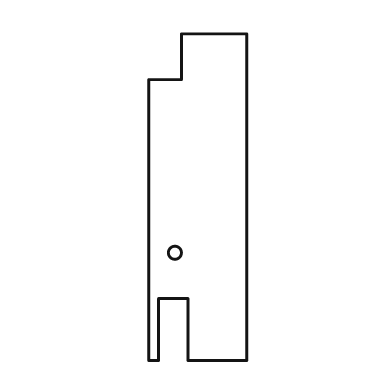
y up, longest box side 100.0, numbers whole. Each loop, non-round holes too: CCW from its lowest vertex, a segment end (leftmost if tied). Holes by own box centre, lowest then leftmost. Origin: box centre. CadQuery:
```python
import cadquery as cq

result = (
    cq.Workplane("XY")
    .moveTo(-15.0, -50.0)
    .lineTo(-12.0, -50.0)
    .lineTo(-12.0, -31.0)
    .lineTo(-3.0, -31.0)
    .lineTo(-3.0, -50.0)
    .lineTo(15.0, -50.0)
    .lineTo(15.0, 50.0)
    .lineTo(-5.0, 50.0)
    .lineTo(-5.0, 36.0)
    .lineTo(-15.0, 36.0)
    .close()
    .moveTo(-7.0, -17.0)
    .circle(2.0)
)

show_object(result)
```